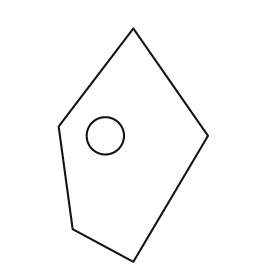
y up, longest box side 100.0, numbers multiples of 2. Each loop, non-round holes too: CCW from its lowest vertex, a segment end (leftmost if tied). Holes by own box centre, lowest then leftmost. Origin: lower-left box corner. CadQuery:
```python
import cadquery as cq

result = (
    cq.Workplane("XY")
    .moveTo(32.0, 0.0)
    .lineTo(64.0, 54.0)
    .lineTo(32.0, 100.0)
    .lineTo(0.0, 58.0)
    .lineTo(6.0, 14.0)
    .close()
    .moveTo(20.0, 54.0)
    .circle(8.0)
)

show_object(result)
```